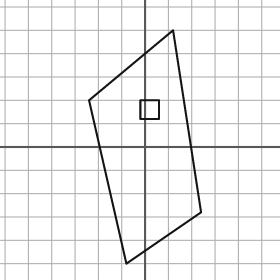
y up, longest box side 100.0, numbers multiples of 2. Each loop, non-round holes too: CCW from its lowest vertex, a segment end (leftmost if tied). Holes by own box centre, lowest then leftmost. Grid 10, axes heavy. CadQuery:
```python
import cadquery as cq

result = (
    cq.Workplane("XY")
    .moveTo(-8.0, -50.0)
    .lineTo(24.0, -28.0)
    .lineTo(12.0, 50.0)
    .lineTo(-24.0, 20.0)
    .close()
    .moveTo(-2.0, 12.0)
    .lineTo(6.0, 12.0)
    .lineTo(6.0, 20.0)
    .lineTo(-2.0, 20.0)
    .close()
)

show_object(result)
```